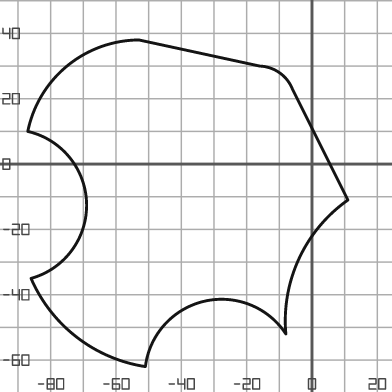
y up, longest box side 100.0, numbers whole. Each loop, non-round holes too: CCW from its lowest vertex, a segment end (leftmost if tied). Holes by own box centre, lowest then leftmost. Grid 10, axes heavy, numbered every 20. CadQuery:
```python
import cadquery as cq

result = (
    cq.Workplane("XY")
    .moveTo(-51.0, -62.0)
    .threePointArc((-33.0, -42.0), (-8.0, -52.0))
    .threePointArc((-4.0, -29.0), (11.0, -11.0))
    .lineTo(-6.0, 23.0)
    .threePointArc((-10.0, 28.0), (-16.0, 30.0))
    .lineTo(-53.0, 38.0)
    .threePointArc((-75.0, 30.0), (-87.0, 10.0))
    .threePointArc((-69.0, -12.0), (-86.0, -35.0))
    .threePointArc((-72.0, -53.0), (-51.0, -62.0))
    .close()
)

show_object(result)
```